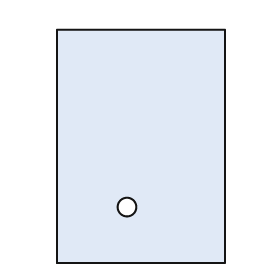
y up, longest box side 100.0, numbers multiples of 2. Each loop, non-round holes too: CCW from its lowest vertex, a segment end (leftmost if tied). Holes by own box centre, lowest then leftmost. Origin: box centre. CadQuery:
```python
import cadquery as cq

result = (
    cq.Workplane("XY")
    .moveTo(-36.0, -50.0)
    .lineTo(36.0, -50.0)
    .lineTo(36.0, 50.0)
    .lineTo(-36.0, 50.0)
    .close()
    .moveTo(-6.0, -26.0)
    .circle(4.0)
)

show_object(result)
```